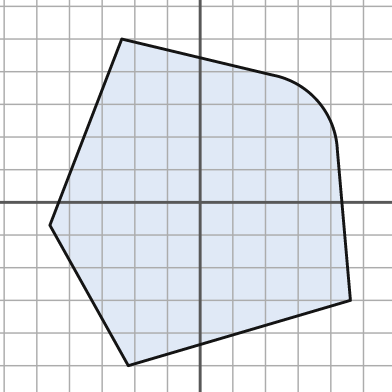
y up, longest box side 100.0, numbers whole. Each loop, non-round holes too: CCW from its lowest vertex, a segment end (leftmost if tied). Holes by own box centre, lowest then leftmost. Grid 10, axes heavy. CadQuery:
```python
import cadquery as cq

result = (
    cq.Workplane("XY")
    .moveTo(-22.0, -50.0)
    .lineTo(46.0, -30.0)
    .lineTo(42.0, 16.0)
    .threePointArc((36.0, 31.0), (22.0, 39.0))
    .lineTo(-24.0, 50.0)
    .lineTo(-46.0, -7.0)
    .close()
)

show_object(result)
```